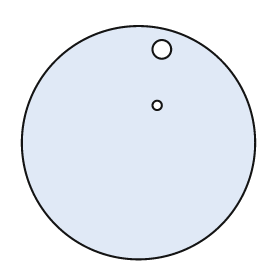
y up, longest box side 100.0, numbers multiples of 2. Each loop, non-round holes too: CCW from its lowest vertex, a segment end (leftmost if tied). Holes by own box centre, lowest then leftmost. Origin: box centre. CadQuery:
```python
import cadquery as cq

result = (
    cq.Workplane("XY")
    .moveTo(0.0, 0.0)
    .circle(50.0)
    .moveTo(8.0, 16.0)
    .circle(2.0)
    .moveTo(10.0, 40.0)
    .circle(4.0)
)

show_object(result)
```